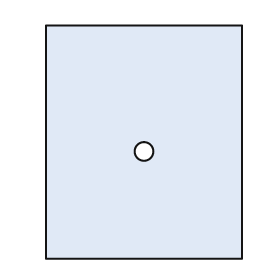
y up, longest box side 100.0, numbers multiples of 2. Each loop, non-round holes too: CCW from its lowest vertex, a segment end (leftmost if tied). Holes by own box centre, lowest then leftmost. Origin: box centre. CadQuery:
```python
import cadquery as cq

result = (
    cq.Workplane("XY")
    .moveTo(-42.0, -50.0)
    .lineTo(42.0, -50.0)
    .lineTo(42.0, 50.0)
    .lineTo(-42.0, 50.0)
    .close()
    .moveTo(0.0, -4.0)
    .circle(4.0)
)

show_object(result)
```